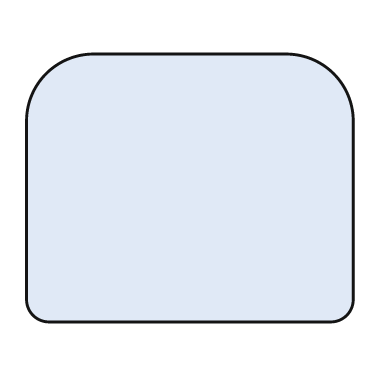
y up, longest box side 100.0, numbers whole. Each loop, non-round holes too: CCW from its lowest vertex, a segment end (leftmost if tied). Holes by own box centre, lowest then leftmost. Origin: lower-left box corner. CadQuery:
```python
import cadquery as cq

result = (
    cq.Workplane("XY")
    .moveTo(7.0, 0.0)
    .lineTo(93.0, 0.0)
    .threePointArc((98.0, 2.0), (100.0, 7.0))
    .lineTo(100.0, 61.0)
    .threePointArc((94.0, 76.0), (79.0, 82.0))
    .lineTo(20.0, 82.0)
    .threePointArc((6.0, 76.0), (0.0, 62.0))
    .lineTo(0.0, 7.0)
    .threePointArc((2.0, 2.0), (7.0, 0.0))
    .close()
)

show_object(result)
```